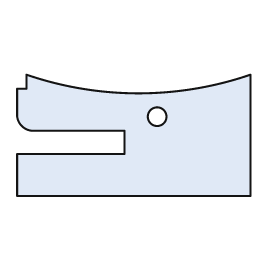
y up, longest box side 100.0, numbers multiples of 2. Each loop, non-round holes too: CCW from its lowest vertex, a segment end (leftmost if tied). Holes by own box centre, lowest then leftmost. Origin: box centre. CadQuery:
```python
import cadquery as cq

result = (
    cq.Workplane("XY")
    .moveTo(-50.0, -26.0)
    .lineTo(50.0, -26.0)
    .lineTo(50.0, 26.0)
    .threePointArc((2.0, 18.0), (-46.0, 26.0))
    .lineTo(-46.0, 20.0)
    .lineTo(-50.0, 20.0)
    .lineTo(-50.0, 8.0)
    .threePointArc((-48.0, 4.0), (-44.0, 2.0))
    .lineTo(-4.0, 2.0)
    .lineTo(-4.0, -8.0)
    .lineTo(-50.0, -8.0)
    .close()
    .moveTo(10.0, 8.0)
    .circle(4.0)
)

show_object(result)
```